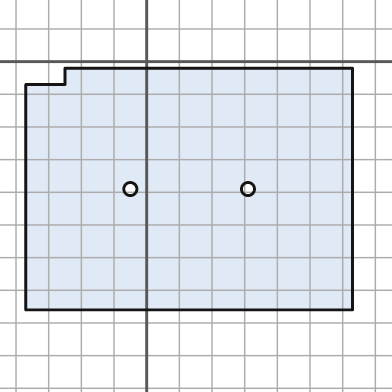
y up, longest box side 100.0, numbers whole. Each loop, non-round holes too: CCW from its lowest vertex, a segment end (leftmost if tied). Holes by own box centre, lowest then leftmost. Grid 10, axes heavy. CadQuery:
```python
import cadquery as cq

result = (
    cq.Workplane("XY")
    .moveTo(-37.0, -76.0)
    .lineTo(63.0, -76.0)
    .lineTo(63.0, -2.0)
    .lineTo(-25.0, -2.0)
    .lineTo(-25.0, -7.0)
    .lineTo(-37.0, -7.0)
    .close()
    .moveTo(-5.0, -39.0)
    .circle(2.0)
    .moveTo(31.0, -39.0)
    .circle(2.0)
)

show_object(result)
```